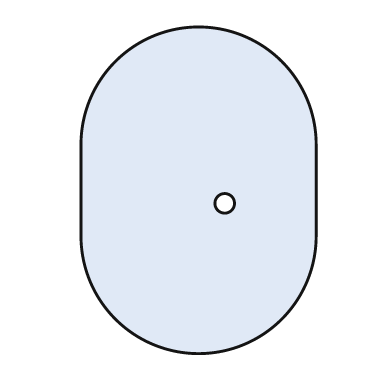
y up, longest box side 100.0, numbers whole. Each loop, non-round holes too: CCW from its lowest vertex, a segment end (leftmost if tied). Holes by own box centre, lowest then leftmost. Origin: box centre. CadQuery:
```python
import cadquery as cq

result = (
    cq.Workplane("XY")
    .moveTo(-36.0, -14.0)
    .threePointArc((0.0, -50.0), (36.0, -14.0))
    .lineTo(36.0, 14.0)
    .threePointArc((0.0, 50.0), (-36.0, 14.0))
    .close()
    .moveTo(8.0, -4.0)
    .circle(3.0)
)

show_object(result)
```